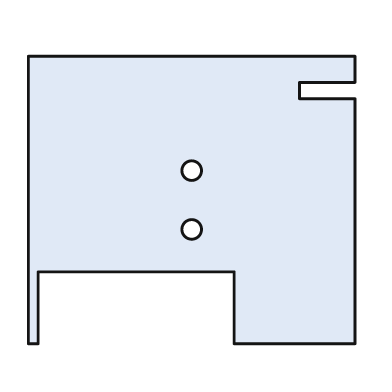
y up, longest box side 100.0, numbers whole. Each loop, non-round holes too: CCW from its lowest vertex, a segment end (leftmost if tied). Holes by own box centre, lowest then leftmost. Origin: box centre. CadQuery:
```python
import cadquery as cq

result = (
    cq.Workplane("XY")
    .moveTo(-50.0, -44.0)
    .lineTo(-47.0, -44.0)
    .lineTo(-47.0, -22.0)
    .lineTo(13.0, -22.0)
    .lineTo(13.0, -44.0)
    .lineTo(50.0, -44.0)
    .lineTo(50.0, 31.0)
    .lineTo(33.0, 31.0)
    .lineTo(33.0, 36.0)
    .lineTo(50.0, 36.0)
    .lineTo(50.0, 44.0)
    .lineTo(-50.0, 44.0)
    .close()
    .moveTo(0.0, -9.0)
    .circle(3.0)
    .moveTo(0.0, 9.0)
    .circle(3.0)
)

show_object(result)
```